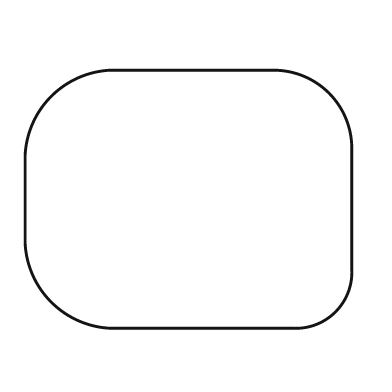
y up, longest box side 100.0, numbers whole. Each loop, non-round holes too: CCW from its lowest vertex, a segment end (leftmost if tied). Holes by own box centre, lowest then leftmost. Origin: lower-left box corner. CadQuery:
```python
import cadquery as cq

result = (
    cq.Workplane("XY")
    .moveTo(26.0, 0.0)
    .lineTo(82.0, 0.0)
    .threePointArc((95.0, 5.0), (100.0, 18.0))
    .lineTo(100.0, 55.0)
    .threePointArc((93.0, 72.0), (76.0, 79.0))
    .lineTo(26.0, 79.0)
    .threePointArc((8.0, 71.0), (0.0, 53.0))
    .lineTo(0.0, 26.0)
    .threePointArc((8.0, 8.0), (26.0, 0.0))
    .close()
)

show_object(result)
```